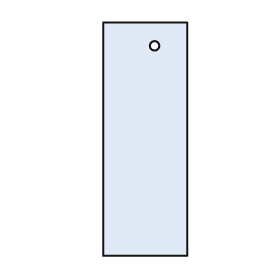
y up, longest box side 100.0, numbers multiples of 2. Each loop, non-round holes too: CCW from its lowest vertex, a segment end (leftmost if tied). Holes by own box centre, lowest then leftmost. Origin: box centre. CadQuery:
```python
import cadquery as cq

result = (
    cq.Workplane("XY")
    .moveTo(-18.0, -50.0)
    .lineTo(18.0, -50.0)
    .lineTo(18.0, 50.0)
    .lineTo(-18.0, 50.0)
    .close()
    .moveTo(4.0, 40.0)
    .circle(2.0)
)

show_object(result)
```